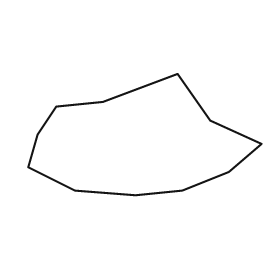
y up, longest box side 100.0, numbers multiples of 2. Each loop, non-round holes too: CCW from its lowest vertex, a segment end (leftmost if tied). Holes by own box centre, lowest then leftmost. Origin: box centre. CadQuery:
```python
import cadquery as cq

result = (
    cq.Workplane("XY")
    .moveTo(-4.0, -26.0)
    .lineTo(16.0, -24.0)
    .lineTo(36.0, -16.0)
    .lineTo(50.0, -4.0)
    .lineTo(28.0, 6.0)
    .lineTo(14.0, 26.0)
    .lineTo(-18.0, 14.0)
    .lineTo(-38.0, 12.0)
    .lineTo(-46.0, 0.0)
    .lineTo(-50.0, -14.0)
    .lineTo(-30.0, -24.0)
    .close()
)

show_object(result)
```